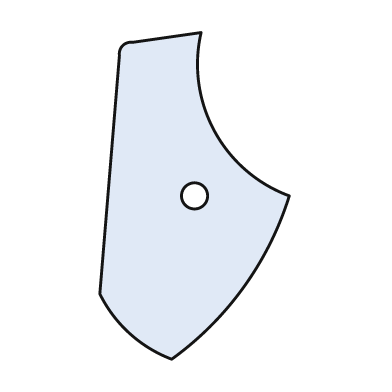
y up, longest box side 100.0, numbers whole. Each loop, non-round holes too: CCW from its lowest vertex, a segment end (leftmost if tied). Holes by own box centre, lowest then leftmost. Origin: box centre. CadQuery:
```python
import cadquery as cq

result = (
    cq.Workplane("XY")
    .moveTo(-7.0, -50.0)
    .threePointArc((15.0, -28.0), (29.0, 0.0))
    .threePointArc((6.0, 20.0), (2.0, 50.0))
    .lineTo(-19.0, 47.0)
    .threePointArc((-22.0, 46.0), (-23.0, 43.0))
    .lineTo(-29.0, -30.0)
    .threePointArc((-20.0, -42.0), (-7.0, -50.0))
    .close()
    .moveTo(0.0, 0.0)
    .circle(4.0)
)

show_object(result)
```